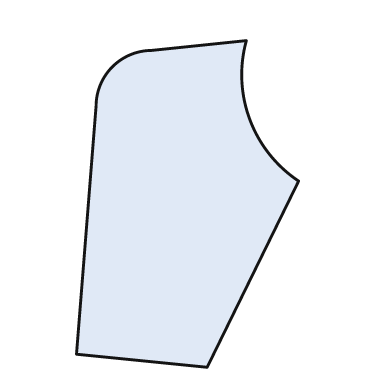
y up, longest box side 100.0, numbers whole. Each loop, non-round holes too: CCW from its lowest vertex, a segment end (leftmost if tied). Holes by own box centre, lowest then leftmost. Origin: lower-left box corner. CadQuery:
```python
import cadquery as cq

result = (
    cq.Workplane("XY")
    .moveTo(40.0, 0.0)
    .lineTo(68.0, 57.0)
    .threePointArc((53.0, 76.0), (52.0, 100.0))
    .lineTo(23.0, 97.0)
    .threePointArc((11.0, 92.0), (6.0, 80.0))
    .lineTo(0.0, 4.0)
    .close()
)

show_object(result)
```